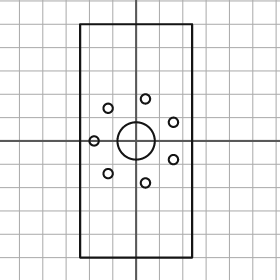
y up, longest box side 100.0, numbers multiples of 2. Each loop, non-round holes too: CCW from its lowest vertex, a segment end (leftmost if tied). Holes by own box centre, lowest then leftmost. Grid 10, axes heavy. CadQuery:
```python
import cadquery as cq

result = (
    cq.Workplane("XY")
    .moveTo(-24.0, -50.0)
    .lineTo(24.0, -50.0)
    .lineTo(24.0, 50.0)
    .lineTo(-24.0, 50.0)
    .close()
    .moveTo(4.0, -18.0)
    .circle(2.0)
    .moveTo(-12.0, -14.0)
    .circle(2.0)
    .moveTo(16.0, -8.0)
    .circle(2.0)
    .moveTo(-18.0, 0.0)
    .circle(2.0)
    .moveTo(0.0, 0.0)
    .circle(8.0)
    .moveTo(16.0, 8.0)
    .circle(2.0)
    .moveTo(-12.0, 14.0)
    .circle(2.0)
    .moveTo(4.0, 18.0)
    .circle(2.0)
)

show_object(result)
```